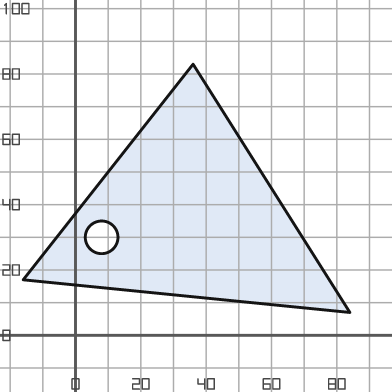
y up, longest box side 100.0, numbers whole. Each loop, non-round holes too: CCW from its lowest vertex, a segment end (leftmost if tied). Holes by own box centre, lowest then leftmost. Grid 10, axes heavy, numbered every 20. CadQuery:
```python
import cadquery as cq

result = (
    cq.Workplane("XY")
    .moveTo(84.0, 7.0)
    .lineTo(36.0, 83.0)
    .lineTo(-16.0, 17.0)
    .close()
    .moveTo(8.0, 30.0)
    .circle(5.0)
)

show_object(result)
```